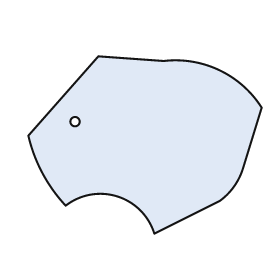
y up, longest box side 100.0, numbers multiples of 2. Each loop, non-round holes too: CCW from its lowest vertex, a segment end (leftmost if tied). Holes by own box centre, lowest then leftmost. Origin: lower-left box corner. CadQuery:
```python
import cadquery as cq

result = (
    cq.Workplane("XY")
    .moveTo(54.0, 0.0)
    .lineTo(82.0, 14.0)
    .threePointArc((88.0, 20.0), (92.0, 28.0))
    .lineTo(100.0, 54.0)
    .threePointArc((82.0, 70.0), (58.0, 74.0))
    .lineTo(30.0, 76.0)
    .lineTo(0.0, 42.0)
    .threePointArc((6.0, 26.0), (16.0, 12.0))
    .threePointArc((38.0, 16.0), (54.0, 0.0))
    .close()
    .moveTo(20.0, 48.0)
    .circle(2.0)
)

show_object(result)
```